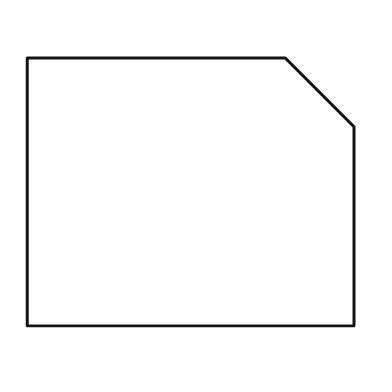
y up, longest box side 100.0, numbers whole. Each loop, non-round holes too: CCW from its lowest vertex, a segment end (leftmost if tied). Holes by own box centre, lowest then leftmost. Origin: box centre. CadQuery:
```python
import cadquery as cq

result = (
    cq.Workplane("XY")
    .moveTo(-50.0, -41.0)
    .lineTo(50.0, -41.0)
    .lineTo(50.0, 20.0)
    .lineTo(29.0, 41.0)
    .lineTo(-50.0, 41.0)
    .close()
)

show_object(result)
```